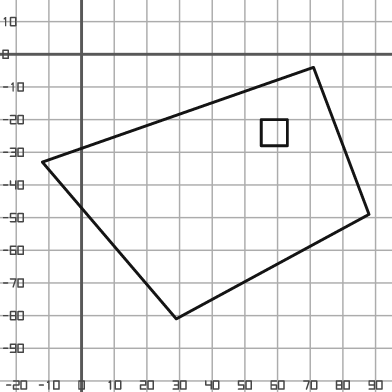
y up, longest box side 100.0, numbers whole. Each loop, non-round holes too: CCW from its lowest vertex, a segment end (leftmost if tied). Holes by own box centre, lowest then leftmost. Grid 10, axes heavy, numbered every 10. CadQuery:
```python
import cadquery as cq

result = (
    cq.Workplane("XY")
    .moveTo(29.0, -81.0)
    .lineTo(88.0, -49.0)
    .lineTo(71.0, -4.0)
    .lineTo(-12.0, -33.0)
    .close()
    .moveTo(55.0, -28.0)
    .lineTo(63.0, -28.0)
    .lineTo(63.0, -20.0)
    .lineTo(55.0, -20.0)
    .close()
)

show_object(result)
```